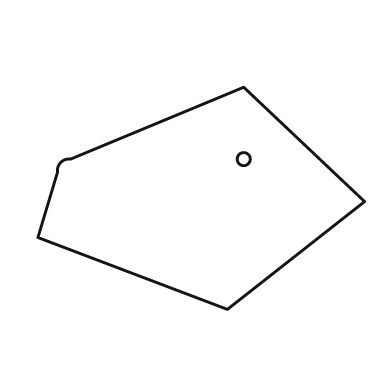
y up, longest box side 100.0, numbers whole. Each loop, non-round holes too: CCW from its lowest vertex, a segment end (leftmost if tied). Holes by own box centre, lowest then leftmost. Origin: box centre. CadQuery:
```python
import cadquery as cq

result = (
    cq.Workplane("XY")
    .moveTo(8.0, -34.0)
    .lineTo(50.0, -1.0)
    .lineTo(13.0, 34.0)
    .lineTo(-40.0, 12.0)
    .threePointArc((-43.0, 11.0), (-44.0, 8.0))
    .lineTo(-50.0, -12.0)
    .close()
    .moveTo(13.0, 12.0)
    .circle(2.0)
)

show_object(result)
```